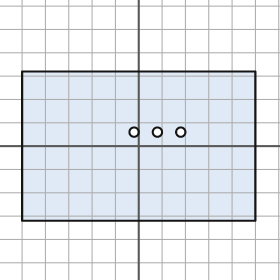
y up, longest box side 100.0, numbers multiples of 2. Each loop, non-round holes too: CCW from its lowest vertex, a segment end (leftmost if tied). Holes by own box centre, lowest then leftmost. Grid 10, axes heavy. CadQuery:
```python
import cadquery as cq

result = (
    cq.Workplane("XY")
    .moveTo(-50.0, -32.0)
    .lineTo(50.0, -32.0)
    .lineTo(50.0, 32.0)
    .lineTo(-50.0, 32.0)
    .close()
    .moveTo(-2.0, 6.0)
    .circle(2.0)
    .moveTo(8.0, 6.0)
    .circle(2.0)
    .moveTo(18.0, 6.0)
    .circle(2.0)
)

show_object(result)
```